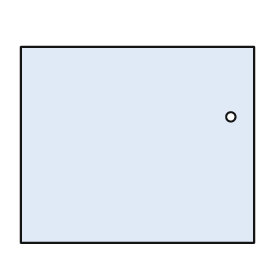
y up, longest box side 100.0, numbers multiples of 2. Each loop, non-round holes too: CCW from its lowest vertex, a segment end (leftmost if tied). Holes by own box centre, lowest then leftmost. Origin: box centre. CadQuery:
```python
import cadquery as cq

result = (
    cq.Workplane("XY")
    .moveTo(-50.0, -42.0)
    .lineTo(50.0, -42.0)
    .lineTo(50.0, 42.0)
    .lineTo(-50.0, 42.0)
    .close()
    .moveTo(40.0, 12.0)
    .circle(2.0)
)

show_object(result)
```